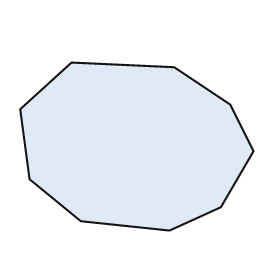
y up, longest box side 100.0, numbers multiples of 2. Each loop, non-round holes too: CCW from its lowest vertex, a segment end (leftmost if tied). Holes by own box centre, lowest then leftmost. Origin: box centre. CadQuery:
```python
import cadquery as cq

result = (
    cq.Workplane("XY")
    .moveTo(14.0, -36.0)
    .lineTo(36.0, -26.0)
    .lineTo(50.0, -2.0)
    .lineTo(40.0, 18.0)
    .lineTo(16.0, 34.0)
    .lineTo(-28.0, 36.0)
    .lineTo(-50.0, 16.0)
    .lineTo(-46.0, -14.0)
    .lineTo(-24.0, -32.0)
    .close()
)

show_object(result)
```